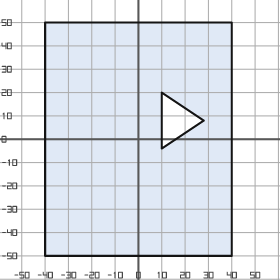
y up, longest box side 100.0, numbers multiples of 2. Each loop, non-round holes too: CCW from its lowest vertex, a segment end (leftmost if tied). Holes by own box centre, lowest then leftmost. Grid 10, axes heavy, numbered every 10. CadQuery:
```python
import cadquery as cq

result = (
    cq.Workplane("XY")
    .moveTo(-40.0, -50.0)
    .lineTo(40.0, -50.0)
    .lineTo(40.0, 50.0)
    .lineTo(-40.0, 50.0)
    .close()
    .moveTo(10.0, -4.0)
    .lineTo(28.0, 8.0)
    .lineTo(10.0, 20.0)
    .close()
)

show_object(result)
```